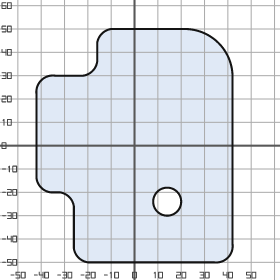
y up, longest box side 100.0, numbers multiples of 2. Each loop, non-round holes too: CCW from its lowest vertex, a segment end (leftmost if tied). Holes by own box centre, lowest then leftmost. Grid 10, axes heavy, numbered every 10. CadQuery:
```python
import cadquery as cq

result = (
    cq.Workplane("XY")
    .moveTo(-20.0, -50.0)
    .lineTo(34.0, -50.0)
    .threePointArc((40.0, -48.0), (42.0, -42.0))
    .lineTo(42.0, 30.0)
    .threePointArc((36.0, 44.0), (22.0, 50.0))
    .lineTo(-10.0, 50.0)
    .threePointArc((-14.0, 48.0), (-16.0, 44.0))
    .lineTo(-16.0, 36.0)
    .threePointArc((-18.0, 32.0), (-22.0, 30.0))
    .lineTo(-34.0, 30.0)
    .threePointArc((-40.0, 28.0), (-42.0, 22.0))
    .lineTo(-42.0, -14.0)
    .threePointArc((-40.0, -18.0), (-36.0, -20.0))
    .lineTo(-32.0, -20.0)
    .threePointArc((-28.0, -22.0), (-26.0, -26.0))
    .lineTo(-26.0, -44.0)
    .threePointArc((-24.0, -48.0), (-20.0, -50.0))
    .close()
    .moveTo(14.0, -24.0)
    .circle(6.0)
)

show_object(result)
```